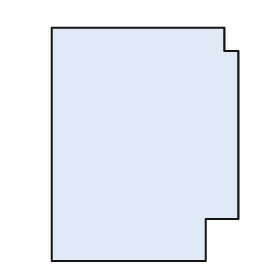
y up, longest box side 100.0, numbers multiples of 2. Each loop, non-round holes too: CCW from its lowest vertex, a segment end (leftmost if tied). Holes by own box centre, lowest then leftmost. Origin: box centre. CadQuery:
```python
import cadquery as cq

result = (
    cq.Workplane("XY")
    .moveTo(-40.0, -50.0)
    .lineTo(26.0, -50.0)
    .lineTo(26.0, -32.0)
    .lineTo(40.0, -32.0)
    .lineTo(40.0, 40.0)
    .lineTo(34.0, 40.0)
    .lineTo(34.0, 50.0)
    .lineTo(-40.0, 50.0)
    .close()
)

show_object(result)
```